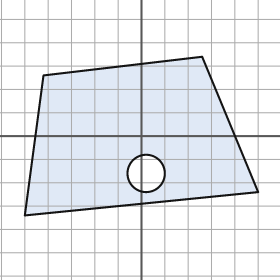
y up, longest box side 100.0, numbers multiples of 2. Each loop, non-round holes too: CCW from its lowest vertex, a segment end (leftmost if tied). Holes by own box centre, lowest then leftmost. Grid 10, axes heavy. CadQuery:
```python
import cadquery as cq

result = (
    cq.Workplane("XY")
    .moveTo(-50.0, -34.0)
    .lineTo(50.0, -24.0)
    .lineTo(26.0, 34.0)
    .lineTo(-42.0, 26.0)
    .close()
    .moveTo(2.0, -16.0)
    .circle(8.0)
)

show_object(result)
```